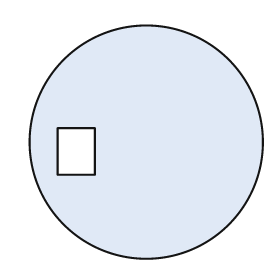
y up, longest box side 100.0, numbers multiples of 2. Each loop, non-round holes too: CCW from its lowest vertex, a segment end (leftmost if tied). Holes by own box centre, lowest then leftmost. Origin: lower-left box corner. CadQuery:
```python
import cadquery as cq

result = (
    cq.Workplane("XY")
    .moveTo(50.0, 50.0)
    .circle(50.0)
    .moveTo(12.0, 36.0)
    .lineTo(28.0, 36.0)
    .lineTo(28.0, 56.0)
    .lineTo(12.0, 56.0)
    .close()
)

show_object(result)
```